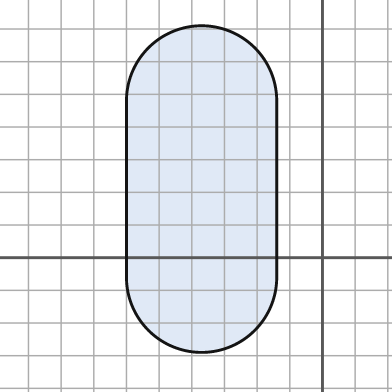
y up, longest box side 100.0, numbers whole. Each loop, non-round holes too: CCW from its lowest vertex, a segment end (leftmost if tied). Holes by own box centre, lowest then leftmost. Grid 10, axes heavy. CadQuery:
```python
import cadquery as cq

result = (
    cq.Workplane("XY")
    .moveTo(-60.0, -6.0)
    .threePointArc((-37.0, -29.0), (-14.0, -6.0))
    .lineTo(-14.0, 48.0)
    .threePointArc((-37.0, 71.0), (-60.0, 48.0))
    .close()
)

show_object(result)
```